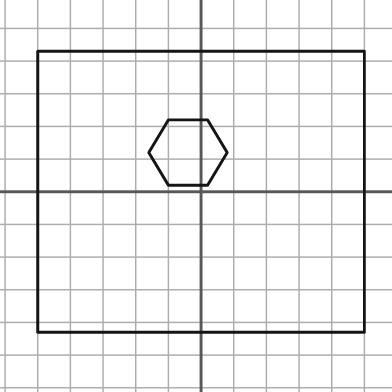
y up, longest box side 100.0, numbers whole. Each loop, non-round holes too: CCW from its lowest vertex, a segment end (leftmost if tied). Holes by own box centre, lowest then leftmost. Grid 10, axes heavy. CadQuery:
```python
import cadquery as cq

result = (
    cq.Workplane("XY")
    .moveTo(-50.0, -43.0)
    .lineTo(50.0, -43.0)
    .lineTo(50.0, 43.0)
    .lineTo(-50.0, 43.0)
    .close()
    .moveTo(-10.0, 2.0)
    .lineTo(2.0, 2.0)
    .lineTo(8.0, 12.0)
    .lineTo(2.0, 22.0)
    .lineTo(-10.0, 22.0)
    .lineTo(-16.0, 12.0)
    .close()
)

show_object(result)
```